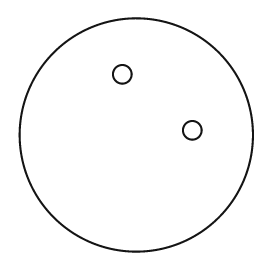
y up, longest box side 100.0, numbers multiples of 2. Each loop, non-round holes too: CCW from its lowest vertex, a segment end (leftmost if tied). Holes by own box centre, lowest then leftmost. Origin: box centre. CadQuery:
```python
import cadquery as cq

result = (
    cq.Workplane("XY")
    .moveTo(0.0, 0.0)
    .circle(50.0)
    .moveTo(24.0, 2.0)
    .circle(4.0)
    .moveTo(-6.0, 26.0)
    .circle(4.0)
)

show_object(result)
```